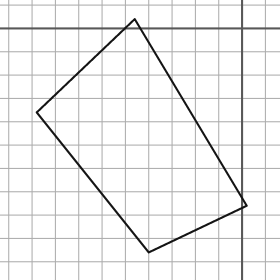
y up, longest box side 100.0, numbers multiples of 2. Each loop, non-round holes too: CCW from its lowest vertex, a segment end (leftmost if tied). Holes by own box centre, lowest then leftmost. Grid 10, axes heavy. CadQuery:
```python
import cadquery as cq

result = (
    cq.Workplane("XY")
    .moveTo(-40.0, -96.0)
    .lineTo(2.0, -76.0)
    .lineTo(-46.0, 4.0)
    .lineTo(-88.0, -36.0)
    .close()
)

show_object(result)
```